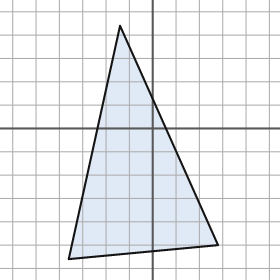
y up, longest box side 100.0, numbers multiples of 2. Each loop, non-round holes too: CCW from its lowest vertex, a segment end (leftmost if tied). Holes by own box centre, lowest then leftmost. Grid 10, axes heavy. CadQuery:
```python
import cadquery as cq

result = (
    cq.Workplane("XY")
    .moveTo(-36.0, -56.0)
    .lineTo(28.0, -50.0)
    .lineTo(-14.0, 44.0)
    .close()
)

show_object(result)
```